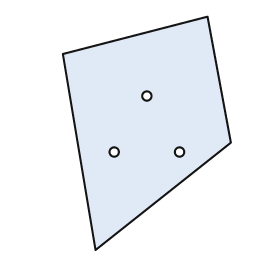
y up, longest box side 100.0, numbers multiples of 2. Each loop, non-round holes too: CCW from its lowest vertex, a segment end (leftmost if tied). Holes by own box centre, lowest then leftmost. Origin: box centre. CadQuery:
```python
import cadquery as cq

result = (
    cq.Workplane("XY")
    .moveTo(-22.0, -50.0)
    .lineTo(36.0, -4.0)
    .lineTo(26.0, 50.0)
    .lineTo(-36.0, 34.0)
    .close()
    .moveTo(-14.0, -8.0)
    .circle(2.0)
    .moveTo(14.0, -8.0)
    .circle(2.0)
    .moveTo(0.0, 16.0)
    .circle(2.0)
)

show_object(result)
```